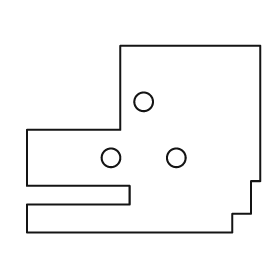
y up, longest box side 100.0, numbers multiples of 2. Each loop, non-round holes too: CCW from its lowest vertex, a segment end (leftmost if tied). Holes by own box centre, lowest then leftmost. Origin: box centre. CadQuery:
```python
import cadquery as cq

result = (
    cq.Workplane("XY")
    .moveTo(-50.0, -40.0)
    .lineTo(38.0, -40.0)
    .lineTo(38.0, -32.0)
    .lineTo(46.0, -32.0)
    .lineTo(46.0, -18.0)
    .lineTo(50.0, -18.0)
    .lineTo(50.0, 40.0)
    .lineTo(-10.0, 40.0)
    .lineTo(-10.0, 4.0)
    .lineTo(-50.0, 4.0)
    .lineTo(-50.0, -20.0)
    .lineTo(-6.0, -20.0)
    .lineTo(-6.0, -28.0)
    .lineTo(-50.0, -28.0)
    .close()
    .moveTo(-14.0, -8.0)
    .circle(4.0)
    .moveTo(14.0, -8.0)
    .circle(4.0)
    .moveTo(0.0, 16.0)
    .circle(4.0)
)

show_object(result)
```